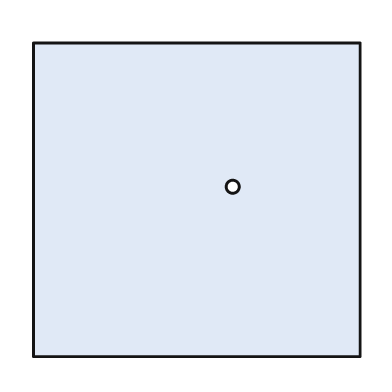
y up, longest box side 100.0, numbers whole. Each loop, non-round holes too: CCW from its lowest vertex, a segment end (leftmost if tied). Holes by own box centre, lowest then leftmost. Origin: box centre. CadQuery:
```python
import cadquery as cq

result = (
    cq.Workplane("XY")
    .moveTo(-50.0, -48.0)
    .lineTo(50.0, -48.0)
    .lineTo(50.0, 48.0)
    .lineTo(-50.0, 48.0)
    .close()
    .moveTo(11.0, 4.0)
    .circle(2.0)
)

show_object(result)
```